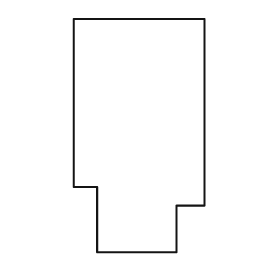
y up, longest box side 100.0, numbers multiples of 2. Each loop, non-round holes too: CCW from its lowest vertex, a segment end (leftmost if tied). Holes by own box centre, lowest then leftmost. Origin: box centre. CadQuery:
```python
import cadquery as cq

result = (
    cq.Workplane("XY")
    .moveTo(-18.0, -50.0)
    .lineTo(16.0, -50.0)
    .lineTo(16.0, -30.0)
    .lineTo(28.0, -30.0)
    .lineTo(28.0, 50.0)
    .lineTo(-28.0, 50.0)
    .lineTo(-28.0, -22.0)
    .lineTo(-18.0, -22.0)
    .close()
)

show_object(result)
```